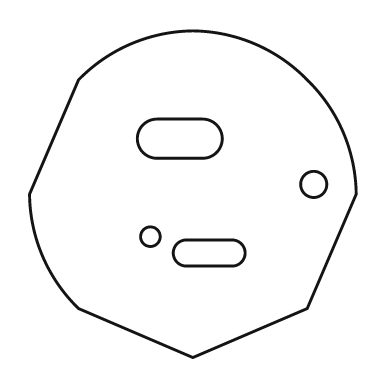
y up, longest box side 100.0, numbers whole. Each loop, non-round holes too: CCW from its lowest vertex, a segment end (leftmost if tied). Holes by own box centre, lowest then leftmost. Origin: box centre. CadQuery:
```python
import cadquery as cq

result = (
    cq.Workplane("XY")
    .moveTo(0.0, -50.0)
    .lineTo(35.0, -35.0)
    .lineTo(50.0, 0.0)
    .threePointArc((46.0, 19.0), (35.0, 35.0))
    .threePointArc((19.0, 46.0), (0.0, 50.0))
    .threePointArc((-19.0, 46.0), (-35.0, 35.0))
    .lineTo(-50.0, 0.0)
    .threePointArc((-46.0, -19.0), (-35.0, -35.0))
    .close()
    .moveTo(-2.0, -22.0)
    .lineTo(12.0, -22.0)
    .threePointArc((16.0, -18.0), (12.0, -14.0))
    .lineTo(-2.0, -14.0)
    .threePointArc((-6.0, -18.0), (-2.0, -22.0))
    .close()
    .moveTo(-13.0, -13.0)
    .circle(3.0)
    .moveTo(37.0, 3.0)
    .circle(4.0)
    .moveTo(-11.0, 11.0)
    .lineTo(3.0, 11.0)
    .threePointArc((9.0, 17.0), (3.0, 23.0))
    .lineTo(-11.0, 23.0)
    .threePointArc((-17.0, 17.0), (-11.0, 11.0))
    .close()
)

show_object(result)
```